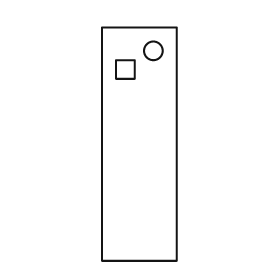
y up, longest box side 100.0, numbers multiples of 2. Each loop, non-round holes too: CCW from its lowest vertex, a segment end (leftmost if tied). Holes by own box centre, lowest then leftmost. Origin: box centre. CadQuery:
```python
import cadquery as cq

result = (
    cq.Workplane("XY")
    .moveTo(-16.0, -50.0)
    .lineTo(16.0, -50.0)
    .lineTo(16.0, 50.0)
    .lineTo(-16.0, 50.0)
    .close()
    .moveTo(-10.0, 28.0)
    .lineTo(-2.0, 28.0)
    .lineTo(-2.0, 36.0)
    .lineTo(-10.0, 36.0)
    .close()
    .moveTo(6.0, 40.0)
    .circle(4.0)
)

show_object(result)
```